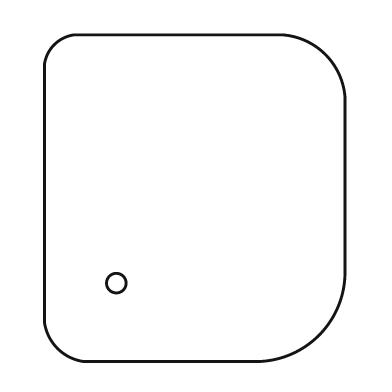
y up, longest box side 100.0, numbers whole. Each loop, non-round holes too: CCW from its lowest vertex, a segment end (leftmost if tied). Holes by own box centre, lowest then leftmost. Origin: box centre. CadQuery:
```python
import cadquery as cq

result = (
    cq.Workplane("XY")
    .moveTo(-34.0, -50.0)
    .lineTo(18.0, -50.0)
    .threePointArc((38.0, -42.0), (46.0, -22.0))
    .lineTo(46.0, 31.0)
    .threePointArc((40.0, 44.0), (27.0, 50.0))
    .lineTo(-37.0, 50.0)
    .threePointArc((-43.0, 47.0), (-46.0, 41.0))
    .lineTo(-46.0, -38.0)
    .threePointArc((-42.0, -46.0), (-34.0, -50.0))
    .close()
    .moveTo(-24.0, -26.0)
    .circle(3.0)
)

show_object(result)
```